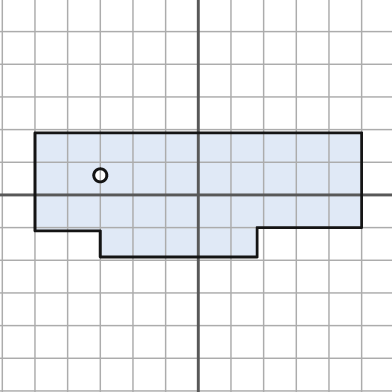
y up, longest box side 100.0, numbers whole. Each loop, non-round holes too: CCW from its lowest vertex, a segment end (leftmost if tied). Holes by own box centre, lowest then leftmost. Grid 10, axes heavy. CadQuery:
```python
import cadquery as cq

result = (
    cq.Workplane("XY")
    .moveTo(-30.0, -19.0)
    .lineTo(18.0, -19.0)
    .lineTo(18.0, -10.0)
    .lineTo(50.0, -10.0)
    .lineTo(50.0, 19.0)
    .lineTo(-50.0, 19.0)
    .lineTo(-50.0, -11.0)
    .lineTo(-30.0, -11.0)
    .close()
    .moveTo(-30.0, 6.0)
    .circle(2.0)
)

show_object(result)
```